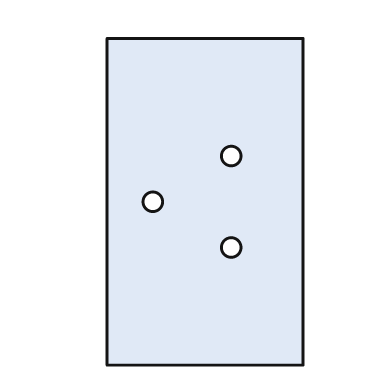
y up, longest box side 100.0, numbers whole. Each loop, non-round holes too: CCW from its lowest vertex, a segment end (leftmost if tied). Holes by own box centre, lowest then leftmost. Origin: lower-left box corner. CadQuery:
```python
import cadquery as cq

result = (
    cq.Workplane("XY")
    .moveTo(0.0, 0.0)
    .lineTo(60.0, 0.0)
    .lineTo(60.0, 100.0)
    .lineTo(0.0, 100.0)
    .close()
    .moveTo(38.0, 36.0)
    .circle(3.0)
    .moveTo(14.0, 50.0)
    .circle(3.0)
    .moveTo(38.0, 64.0)
    .circle(3.0)
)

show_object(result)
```